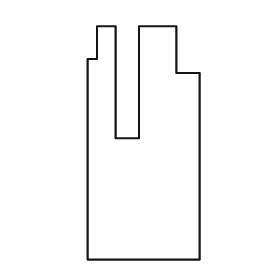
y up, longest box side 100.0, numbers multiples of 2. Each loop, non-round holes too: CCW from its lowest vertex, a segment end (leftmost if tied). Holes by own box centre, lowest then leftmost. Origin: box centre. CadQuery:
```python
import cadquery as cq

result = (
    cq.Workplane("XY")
    .moveTo(-24.0, -50.0)
    .lineTo(24.0, -50.0)
    .lineTo(24.0, 30.0)
    .lineTo(14.0, 30.0)
    .lineTo(14.0, 50.0)
    .lineTo(-2.0, 50.0)
    .lineTo(-2.0, 2.0)
    .lineTo(-12.0, 2.0)
    .lineTo(-12.0, 50.0)
    .lineTo(-20.0, 50.0)
    .lineTo(-20.0, 36.0)
    .lineTo(-24.0, 36.0)
    .close()
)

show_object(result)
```